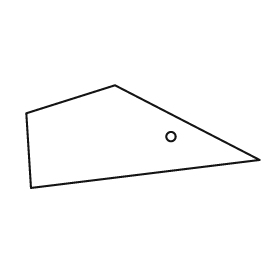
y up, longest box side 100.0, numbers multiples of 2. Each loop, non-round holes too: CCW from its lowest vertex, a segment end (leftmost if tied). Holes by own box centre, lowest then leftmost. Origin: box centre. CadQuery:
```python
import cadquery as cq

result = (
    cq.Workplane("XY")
    .moveTo(-48.0, -22.0)
    .lineTo(50.0, -10.0)
    .lineTo(-12.0, 22.0)
    .lineTo(-50.0, 10.0)
    .close()
    .moveTo(12.0, 0.0)
    .circle(2.0)
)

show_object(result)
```